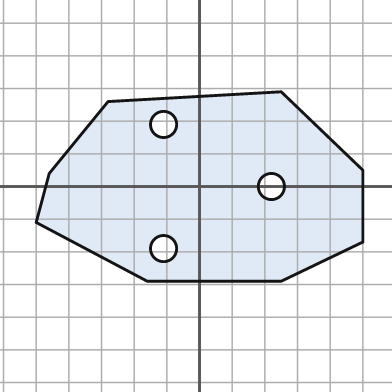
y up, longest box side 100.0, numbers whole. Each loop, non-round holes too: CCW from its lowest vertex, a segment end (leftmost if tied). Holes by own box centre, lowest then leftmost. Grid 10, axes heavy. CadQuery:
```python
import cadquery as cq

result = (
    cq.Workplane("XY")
    .moveTo(-16.0, -29.0)
    .lineTo(25.0, -29.0)
    .lineTo(50.0, -17.0)
    .lineTo(50.0, 5.0)
    .lineTo(25.0, 29.0)
    .lineTo(-28.0, 26.0)
    .lineTo(-46.0, 4.0)
    .lineTo(-50.0, -11.0)
    .close()
    .moveTo(-11.0, -19.0)
    .circle(4.0)
    .moveTo(22.0, 0.0)
    .circle(4.0)
    .moveTo(-11.0, 19.0)
    .circle(4.0)
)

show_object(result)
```